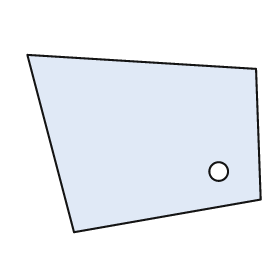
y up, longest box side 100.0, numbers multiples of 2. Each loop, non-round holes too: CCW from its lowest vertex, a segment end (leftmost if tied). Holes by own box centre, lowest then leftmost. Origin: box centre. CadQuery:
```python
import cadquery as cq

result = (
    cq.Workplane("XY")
    .moveTo(-30.0, -38.0)
    .lineTo(50.0, -24.0)
    .lineTo(48.0, 32.0)
    .lineTo(-50.0, 38.0)
    .close()
    .moveTo(32.0, -12.0)
    .circle(4.0)
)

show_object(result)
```